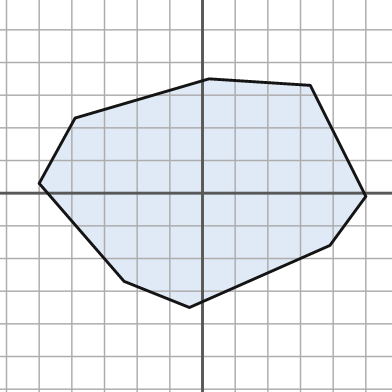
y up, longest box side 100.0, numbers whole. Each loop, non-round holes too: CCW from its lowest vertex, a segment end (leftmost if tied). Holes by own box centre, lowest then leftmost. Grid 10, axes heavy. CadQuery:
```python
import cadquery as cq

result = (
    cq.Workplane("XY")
    .moveTo(-4.0, -35.0)
    .lineTo(39.0, -16.0)
    .lineTo(50.0, -1.0)
    .lineTo(33.0, 33.0)
    .lineTo(2.0, 35.0)
    .lineTo(-39.0, 23.0)
    .lineTo(-50.0, 3.0)
    .lineTo(-24.0, -27.0)
    .close()
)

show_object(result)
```